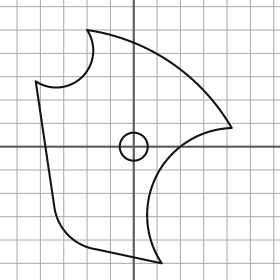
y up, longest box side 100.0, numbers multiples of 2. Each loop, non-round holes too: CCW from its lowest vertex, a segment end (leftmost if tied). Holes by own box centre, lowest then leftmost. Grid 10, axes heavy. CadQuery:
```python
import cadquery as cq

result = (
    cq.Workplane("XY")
    .moveTo(12.0, -50.0)
    .threePointArc((10.0, -12.0), (42.0, 8.0))
    .threePointArc((16.0, 36.0), (-20.0, 50.0))
    .threePointArc((-22.0, 30.0), (-42.0, 28.0))
    .lineTo(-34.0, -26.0)
    .threePointArc((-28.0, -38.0), (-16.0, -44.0))
    .close()
    .moveTo(0.0, 0.0)
    .circle(6.0)
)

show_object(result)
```